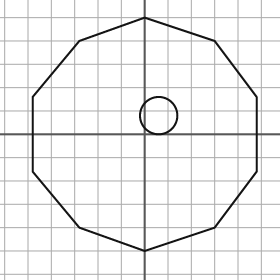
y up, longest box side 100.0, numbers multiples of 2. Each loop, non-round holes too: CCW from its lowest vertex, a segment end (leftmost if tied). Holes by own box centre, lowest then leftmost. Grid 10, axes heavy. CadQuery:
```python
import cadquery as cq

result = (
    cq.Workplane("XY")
    .moveTo(0.0, -50.0)
    .lineTo(30.0, -40.0)
    .lineTo(48.0, -16.0)
    .lineTo(48.0, 16.0)
    .lineTo(30.0, 40.0)
    .lineTo(0.0, 50.0)
    .lineTo(-28.0, 40.0)
    .lineTo(-48.0, 16.0)
    .lineTo(-48.0, -16.0)
    .lineTo(-28.0, -40.0)
    .close()
    .moveTo(6.0, 8.0)
    .circle(8.0)
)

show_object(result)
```